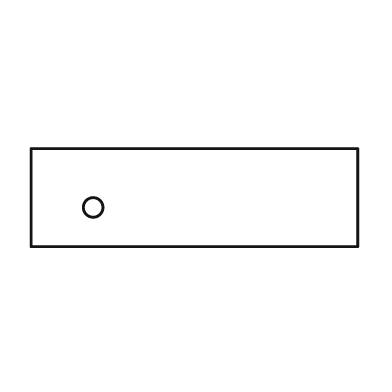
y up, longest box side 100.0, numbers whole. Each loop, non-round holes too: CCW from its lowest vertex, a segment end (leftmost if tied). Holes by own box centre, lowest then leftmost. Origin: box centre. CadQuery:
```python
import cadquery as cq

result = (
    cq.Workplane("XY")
    .moveTo(-50.0, -15.0)
    .lineTo(50.0, -15.0)
    .lineTo(50.0, 15.0)
    .lineTo(-50.0, 15.0)
    .close()
    .moveTo(-31.0, -3.0)
    .circle(3.0)
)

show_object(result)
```